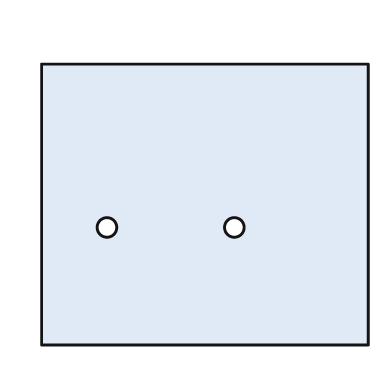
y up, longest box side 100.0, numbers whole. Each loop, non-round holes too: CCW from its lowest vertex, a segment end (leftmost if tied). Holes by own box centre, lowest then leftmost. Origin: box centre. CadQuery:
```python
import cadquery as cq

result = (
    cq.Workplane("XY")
    .moveTo(-50.0, -43.0)
    .lineTo(50.0, -43.0)
    .lineTo(50.0, 43.0)
    .lineTo(-50.0, 43.0)
    .close()
    .moveTo(-30.0, -7.0)
    .circle(3.0)
    .moveTo(9.0, -7.0)
    .circle(3.0)
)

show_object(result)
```